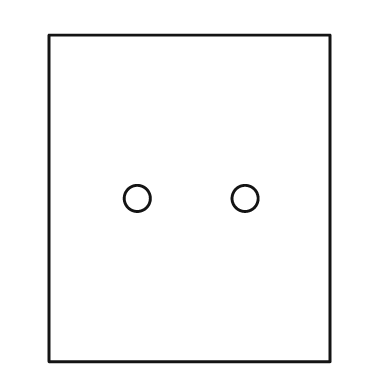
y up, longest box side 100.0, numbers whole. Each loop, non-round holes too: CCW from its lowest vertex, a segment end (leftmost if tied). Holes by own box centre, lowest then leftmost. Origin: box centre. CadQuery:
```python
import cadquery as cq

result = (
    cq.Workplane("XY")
    .moveTo(-43.0, -50.0)
    .lineTo(43.0, -50.0)
    .lineTo(43.0, 50.0)
    .lineTo(-43.0, 50.0)
    .close()
    .moveTo(-16.0, 0.0)
    .circle(4.0)
    .moveTo(17.0, 0.0)
    .circle(4.0)
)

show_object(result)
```